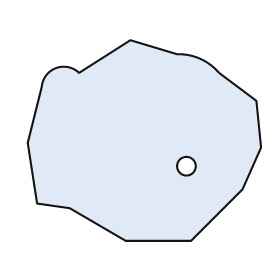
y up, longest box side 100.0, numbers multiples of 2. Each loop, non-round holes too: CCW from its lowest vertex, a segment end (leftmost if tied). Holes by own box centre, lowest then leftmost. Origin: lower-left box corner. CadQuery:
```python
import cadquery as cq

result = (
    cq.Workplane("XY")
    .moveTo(42.0, 0.0)
    .lineTo(70.0, 0.0)
    .lineTo(92.0, 22.0)
    .lineTo(100.0, 40.0)
    .lineTo(98.0, 60.0)
    .lineTo(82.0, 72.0)
    .threePointArc((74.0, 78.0), (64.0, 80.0))
    .lineTo(44.0, 86.0)
    .lineTo(22.0, 72.0)
    .threePointArc((12.0, 74.0), (6.0, 66.0))
    .lineTo(0.0, 42.0)
    .lineTo(4.0, 16.0)
    .lineTo(18.0, 14.0)
    .close()
    .moveTo(68.0, 32.0)
    .circle(4.0)
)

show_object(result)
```